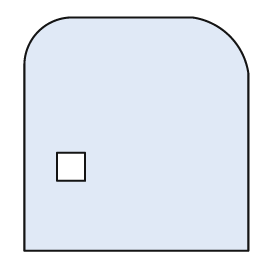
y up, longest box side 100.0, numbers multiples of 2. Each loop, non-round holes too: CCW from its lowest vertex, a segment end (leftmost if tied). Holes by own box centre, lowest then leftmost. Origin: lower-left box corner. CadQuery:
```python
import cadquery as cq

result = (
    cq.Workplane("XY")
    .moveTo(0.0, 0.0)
    .lineTo(96.0, 0.0)
    .lineTo(96.0, 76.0)
    .threePointArc((88.0, 92.0), (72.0, 100.0))
    .lineTo(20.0, 100.0)
    .threePointArc((6.0, 94.0), (0.0, 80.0))
    .close()
    .moveTo(14.0, 30.0)
    .lineTo(26.0, 30.0)
    .lineTo(26.0, 42.0)
    .lineTo(14.0, 42.0)
    .close()
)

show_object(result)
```